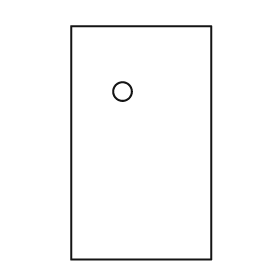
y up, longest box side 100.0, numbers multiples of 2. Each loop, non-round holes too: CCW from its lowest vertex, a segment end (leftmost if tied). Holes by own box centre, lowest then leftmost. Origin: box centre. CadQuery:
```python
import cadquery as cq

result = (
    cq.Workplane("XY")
    .moveTo(-30.0, -50.0)
    .lineTo(30.0, -50.0)
    .lineTo(30.0, 50.0)
    .lineTo(-30.0, 50.0)
    .close()
    .moveTo(-8.0, 22.0)
    .circle(4.0)
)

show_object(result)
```